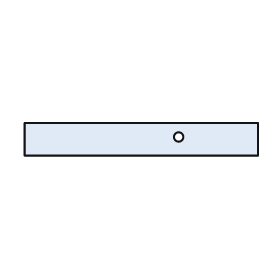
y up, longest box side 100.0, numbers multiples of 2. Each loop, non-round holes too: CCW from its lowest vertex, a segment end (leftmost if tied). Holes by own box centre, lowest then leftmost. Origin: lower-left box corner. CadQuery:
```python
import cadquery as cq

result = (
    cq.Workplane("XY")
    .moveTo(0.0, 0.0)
    .lineTo(100.0, 0.0)
    .lineTo(100.0, 14.0)
    .lineTo(0.0, 14.0)
    .close()
    .moveTo(66.0, 8.0)
    .circle(2.0)
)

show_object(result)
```